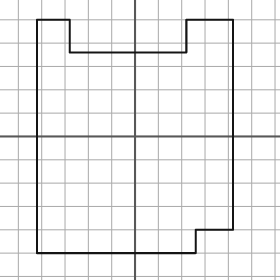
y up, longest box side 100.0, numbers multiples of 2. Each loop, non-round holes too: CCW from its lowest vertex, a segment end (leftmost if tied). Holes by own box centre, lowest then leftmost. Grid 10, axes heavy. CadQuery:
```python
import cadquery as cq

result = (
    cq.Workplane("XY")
    .moveTo(-42.0, -50.0)
    .lineTo(26.0, -50.0)
    .lineTo(26.0, -40.0)
    .lineTo(42.0, -40.0)
    .lineTo(42.0, 50.0)
    .lineTo(22.0, 50.0)
    .lineTo(22.0, 36.0)
    .lineTo(-28.0, 36.0)
    .lineTo(-28.0, 50.0)
    .lineTo(-42.0, 50.0)
    .close()
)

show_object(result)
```